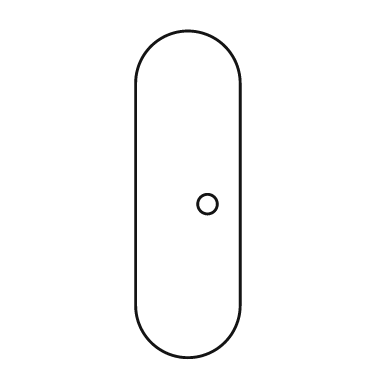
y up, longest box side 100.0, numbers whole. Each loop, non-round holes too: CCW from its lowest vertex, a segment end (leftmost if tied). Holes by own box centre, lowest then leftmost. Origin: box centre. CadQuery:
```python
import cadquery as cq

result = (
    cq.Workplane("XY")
    .moveTo(-16.0, -34.0)
    .threePointArc((0.0, -50.0), (16.0, -34.0))
    .lineTo(16.0, 34.0)
    .threePointArc((0.0, 50.0), (-16.0, 34.0))
    .close()
    .moveTo(6.0, -3.0)
    .circle(3.0)
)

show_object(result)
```